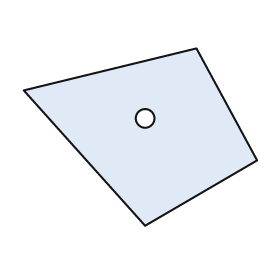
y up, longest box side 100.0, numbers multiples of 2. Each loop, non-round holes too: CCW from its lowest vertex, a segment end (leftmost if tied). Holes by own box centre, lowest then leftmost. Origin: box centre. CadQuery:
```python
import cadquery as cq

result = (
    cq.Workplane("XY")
    .moveTo(2.0, -38.0)
    .lineTo(50.0, -10.0)
    .lineTo(24.0, 38.0)
    .lineTo(-50.0, 20.0)
    .close()
    .moveTo(2.0, 8.0)
    .circle(4.0)
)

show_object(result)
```